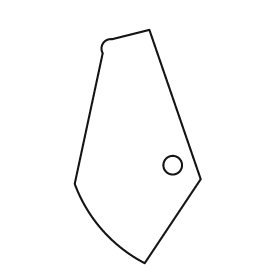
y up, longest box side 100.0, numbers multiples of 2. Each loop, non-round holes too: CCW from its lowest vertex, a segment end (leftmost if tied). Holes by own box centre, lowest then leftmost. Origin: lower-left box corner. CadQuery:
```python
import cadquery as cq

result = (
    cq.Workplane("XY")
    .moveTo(30.0, 0.0)
    .lineTo(54.0, 36.0)
    .lineTo(32.0, 100.0)
    .lineTo(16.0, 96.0)
    .threePointArc((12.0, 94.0), (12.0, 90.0))
    .lineTo(0.0, 34.0)
    .threePointArc((12.0, 14.0), (30.0, 0.0))
    .close()
    .moveTo(42.0, 42.0)
    .circle(4.0)
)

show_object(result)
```